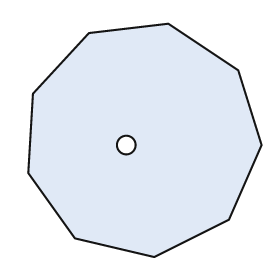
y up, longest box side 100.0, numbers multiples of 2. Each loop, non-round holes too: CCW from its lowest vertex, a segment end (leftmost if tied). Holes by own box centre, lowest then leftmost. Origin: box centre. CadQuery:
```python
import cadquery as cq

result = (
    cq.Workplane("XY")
    .moveTo(4.0, -50.0)
    .lineTo(36.0, -34.0)
    .lineTo(50.0, -2.0)
    .lineTo(40.0, 30.0)
    .lineTo(10.0, 50.0)
    .lineTo(-24.0, 46.0)
    .lineTo(-48.0, 20.0)
    .lineTo(-50.0, -14.0)
    .lineTo(-30.0, -42.0)
    .close()
    .moveTo(-8.0, -2.0)
    .circle(4.0)
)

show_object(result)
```